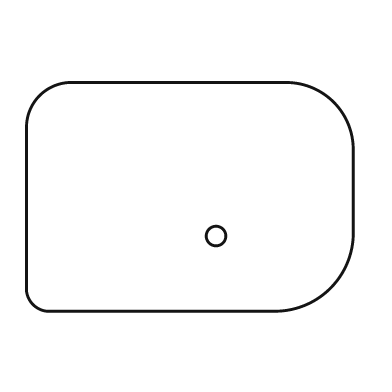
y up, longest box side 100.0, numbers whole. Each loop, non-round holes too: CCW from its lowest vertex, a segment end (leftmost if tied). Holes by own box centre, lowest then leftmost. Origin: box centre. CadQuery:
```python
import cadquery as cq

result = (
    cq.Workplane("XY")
    .moveTo(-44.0, -35.0)
    .lineTo(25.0, -35.0)
    .threePointArc((43.0, -28.0), (50.0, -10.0))
    .lineTo(50.0, 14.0)
    .threePointArc((44.0, 29.0), (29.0, 35.0))
    .lineTo(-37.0, 35.0)
    .threePointArc((-46.0, 31.0), (-50.0, 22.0))
    .lineTo(-50.0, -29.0)
    .threePointArc((-48.0, -33.0), (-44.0, -35.0))
    .close()
    .moveTo(8.0, -12.0)
    .circle(3.0)
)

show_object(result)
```